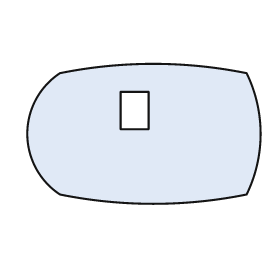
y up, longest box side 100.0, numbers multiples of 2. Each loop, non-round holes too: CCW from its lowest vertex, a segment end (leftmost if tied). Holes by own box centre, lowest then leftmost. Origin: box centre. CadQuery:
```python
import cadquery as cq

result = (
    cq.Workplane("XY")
    .moveTo(-36.0, -26.0)
    .threePointArc((4.0, -30.0), (44.0, -26.0))
    .threePointArc((50.0, 0.0), (44.0, 26.0))
    .threePointArc((4.0, 30.0), (-36.0, 26.0))
    .threePointArc((-50.0, 0.0), (-36.0, -26.0))
    .close()
    .moveTo(-10.0, 2.0)
    .lineTo(2.0, 2.0)
    .lineTo(2.0, 18.0)
    .lineTo(-10.0, 18.0)
    .close()
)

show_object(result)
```